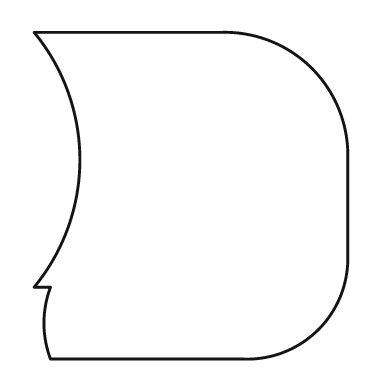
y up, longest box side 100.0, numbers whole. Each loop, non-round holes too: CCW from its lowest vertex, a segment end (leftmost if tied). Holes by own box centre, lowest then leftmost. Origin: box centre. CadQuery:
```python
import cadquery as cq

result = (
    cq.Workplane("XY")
    .moveTo(-43.0, -50.0)
    .lineTo(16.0, -50.0)
    .threePointArc((39.0, -41.0), (48.0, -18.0))
    .lineTo(48.0, 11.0)
    .threePointArc((37.0, 39.0), (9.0, 50.0))
    .lineTo(-48.0, 50.0)
    .threePointArc((-34.0, 11.0), (-48.0, -28.0))
    .lineTo(-43.0, -28.0)
    .threePointArc((-45.0, -39.0), (-43.0, -50.0))
    .close()
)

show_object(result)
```